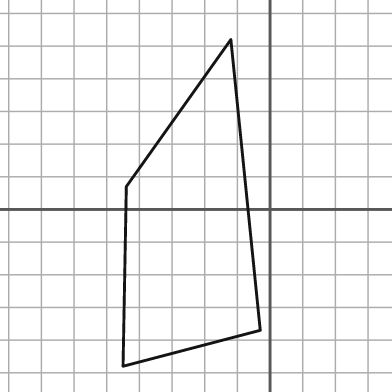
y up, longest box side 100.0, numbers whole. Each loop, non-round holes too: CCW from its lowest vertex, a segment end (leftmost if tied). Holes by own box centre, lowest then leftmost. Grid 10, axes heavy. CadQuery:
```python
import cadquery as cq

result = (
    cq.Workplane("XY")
    .moveTo(-45.0, -48.0)
    .lineTo(-3.0, -37.0)
    .lineTo(-12.0, 52.0)
    .lineTo(-44.0, 7.0)
    .close()
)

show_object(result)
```